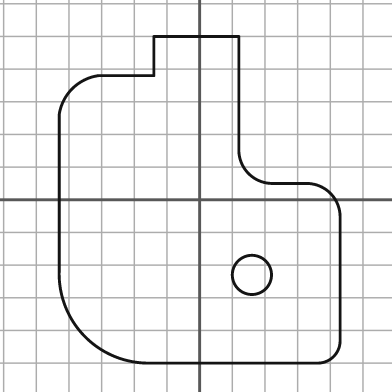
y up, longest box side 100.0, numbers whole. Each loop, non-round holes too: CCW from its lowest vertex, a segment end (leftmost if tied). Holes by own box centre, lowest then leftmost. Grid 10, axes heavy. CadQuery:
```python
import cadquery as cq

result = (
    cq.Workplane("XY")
    .moveTo(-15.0, -50.0)
    .lineTo(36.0, -50.0)
    .threePointArc((41.0, -48.0), (43.0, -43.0))
    .lineTo(43.0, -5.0)
    .threePointArc((40.0, 2.0), (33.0, 5.0))
    .lineTo(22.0, 5.0)
    .threePointArc((15.0, 8.0), (12.0, 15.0))
    .lineTo(12.0, 50.0)
    .lineTo(-14.0, 50.0)
    .lineTo(-14.0, 38.0)
    .lineTo(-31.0, 38.0)
    .threePointArc((-39.0, 34.0), (-43.0, 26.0))
    .lineTo(-43.0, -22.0)
    .threePointArc((-35.0, -42.0), (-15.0, -50.0))
    .close()
    .moveTo(16.0, -23.0)
    .circle(6.0)
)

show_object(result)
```